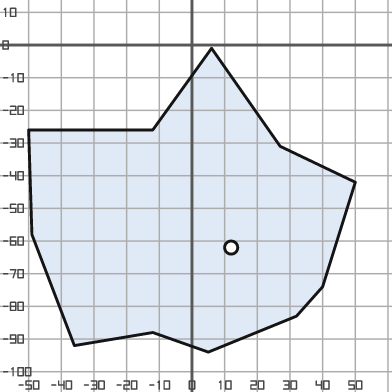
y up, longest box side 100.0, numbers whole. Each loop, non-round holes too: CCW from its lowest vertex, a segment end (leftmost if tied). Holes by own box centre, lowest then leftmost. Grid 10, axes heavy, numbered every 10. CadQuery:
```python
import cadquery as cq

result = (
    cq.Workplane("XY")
    .moveTo(5.0, -94.0)
    .lineTo(32.0, -83.0)
    .lineTo(40.0, -74.0)
    .lineTo(50.0, -42.0)
    .lineTo(27.0, -31.0)
    .lineTo(6.0, -1.0)
    .lineTo(-12.0, -26.0)
    .lineTo(-50.0, -26.0)
    .lineTo(-49.0, -58.0)
    .lineTo(-36.0, -92.0)
    .lineTo(-12.0, -88.0)
    .close()
    .moveTo(12.0, -62.0)
    .circle(2.0)
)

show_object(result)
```